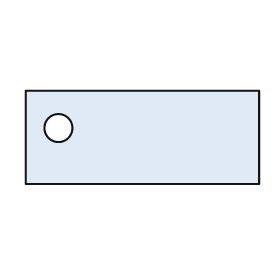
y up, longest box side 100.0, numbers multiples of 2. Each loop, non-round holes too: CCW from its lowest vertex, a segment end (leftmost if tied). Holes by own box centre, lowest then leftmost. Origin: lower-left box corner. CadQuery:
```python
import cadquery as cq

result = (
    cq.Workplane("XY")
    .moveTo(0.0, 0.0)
    .lineTo(100.0, 0.0)
    .lineTo(100.0, 40.0)
    .lineTo(0.0, 40.0)
    .close()
    .moveTo(14.0, 24.0)
    .circle(6.0)
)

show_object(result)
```